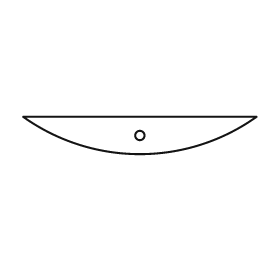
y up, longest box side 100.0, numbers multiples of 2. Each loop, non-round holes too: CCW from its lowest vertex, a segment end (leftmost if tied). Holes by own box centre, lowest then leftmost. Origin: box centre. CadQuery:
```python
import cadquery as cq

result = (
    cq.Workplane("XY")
    .moveTo(-50.0, 8.0)
    .threePointArc((0.0, -8.0), (50.0, 8.0))
    .close()
    .moveTo(0.0, 0.0)
    .circle(2.0)
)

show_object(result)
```